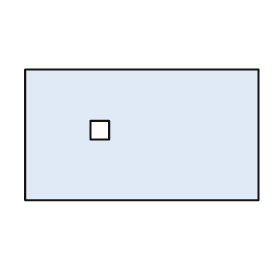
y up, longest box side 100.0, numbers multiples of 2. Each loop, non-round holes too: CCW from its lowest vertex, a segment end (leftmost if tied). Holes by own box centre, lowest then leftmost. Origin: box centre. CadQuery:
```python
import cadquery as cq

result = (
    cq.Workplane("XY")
    .moveTo(-50.0, -28.0)
    .lineTo(50.0, -28.0)
    .lineTo(50.0, 28.0)
    .lineTo(-50.0, 28.0)
    .close()
    .moveTo(-22.0, -2.0)
    .lineTo(-14.0, -2.0)
    .lineTo(-14.0, 6.0)
    .lineTo(-22.0, 6.0)
    .close()
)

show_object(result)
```